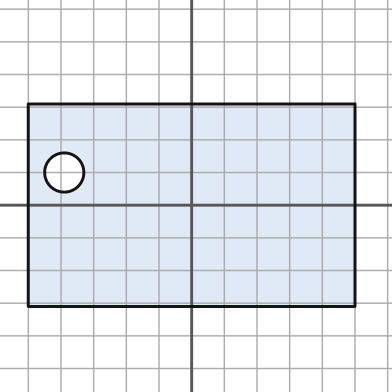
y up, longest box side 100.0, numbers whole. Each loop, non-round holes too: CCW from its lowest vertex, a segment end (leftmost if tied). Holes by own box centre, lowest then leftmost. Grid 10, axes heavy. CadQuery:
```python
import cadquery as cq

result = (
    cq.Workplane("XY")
    .moveTo(-50.0, -31.0)
    .lineTo(50.0, -31.0)
    .lineTo(50.0, 31.0)
    .lineTo(-50.0, 31.0)
    .close()
    .moveTo(-39.0, 10.0)
    .circle(6.0)
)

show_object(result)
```